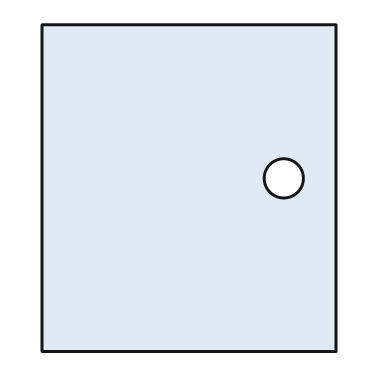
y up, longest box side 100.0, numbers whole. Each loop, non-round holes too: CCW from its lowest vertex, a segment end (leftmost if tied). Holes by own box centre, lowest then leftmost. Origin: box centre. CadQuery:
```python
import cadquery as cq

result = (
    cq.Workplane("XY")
    .moveTo(-45.0, -50.0)
    .lineTo(45.0, -50.0)
    .lineTo(45.0, 50.0)
    .lineTo(-45.0, 50.0)
    .close()
    .moveTo(29.0, 3.0)
    .circle(6.0)
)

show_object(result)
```